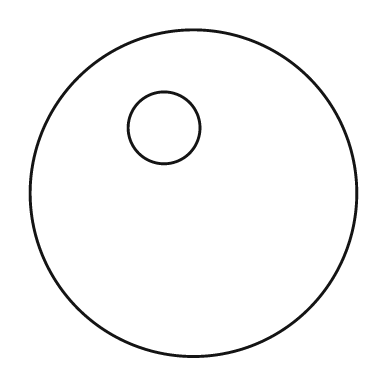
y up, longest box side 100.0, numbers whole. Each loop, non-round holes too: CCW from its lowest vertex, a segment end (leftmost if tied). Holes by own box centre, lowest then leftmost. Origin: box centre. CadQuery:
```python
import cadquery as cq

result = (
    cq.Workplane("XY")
    .moveTo(0.0, 0.0)
    .circle(50.0)
    .moveTo(-9.0, 20.0)
    .circle(11.0)
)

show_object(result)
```